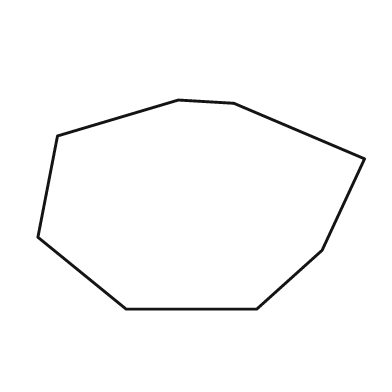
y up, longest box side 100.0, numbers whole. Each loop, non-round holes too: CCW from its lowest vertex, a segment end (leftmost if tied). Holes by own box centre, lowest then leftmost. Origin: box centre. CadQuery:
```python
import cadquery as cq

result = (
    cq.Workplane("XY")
    .moveTo(-23.0, -32.0)
    .lineTo(17.0, -32.0)
    .lineTo(37.0, -14.0)
    .lineTo(50.0, 14.0)
    .lineTo(10.0, 31.0)
    .lineTo(-7.0, 32.0)
    .lineTo(-44.0, 21.0)
    .lineTo(-50.0, -10.0)
    .close()
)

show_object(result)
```